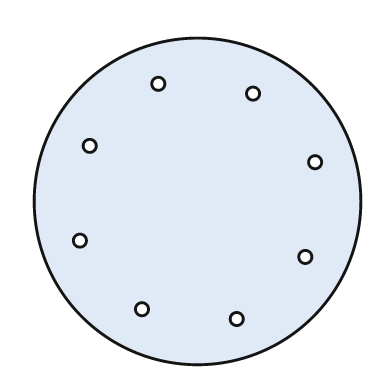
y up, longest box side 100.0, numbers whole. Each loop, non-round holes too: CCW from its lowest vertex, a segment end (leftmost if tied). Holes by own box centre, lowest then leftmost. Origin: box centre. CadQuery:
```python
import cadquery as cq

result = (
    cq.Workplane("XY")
    .moveTo(0.0, 0.0)
    .circle(50.0)
    .moveTo(12.0, -36.0)
    .circle(2.0)
    .moveTo(-17.0, -33.0)
    .circle(2.0)
    .moveTo(33.0, -17.0)
    .circle(2.0)
    .moveTo(-36.0, -12.0)
    .circle(2.0)
    .moveTo(36.0, 12.0)
    .circle(2.0)
    .moveTo(-33.0, 17.0)
    .circle(2.0)
    .moveTo(17.0, 33.0)
    .circle(2.0)
    .moveTo(-12.0, 36.0)
    .circle(2.0)
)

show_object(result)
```